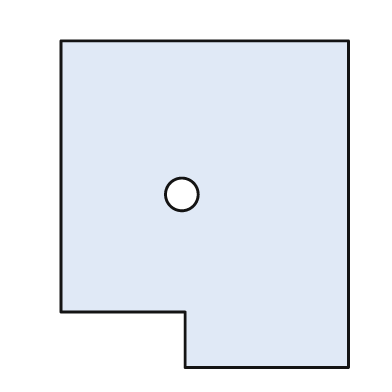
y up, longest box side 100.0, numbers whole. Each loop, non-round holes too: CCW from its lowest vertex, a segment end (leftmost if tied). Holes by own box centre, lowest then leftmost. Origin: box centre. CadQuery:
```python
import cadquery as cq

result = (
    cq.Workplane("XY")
    .moveTo(-6.0, -50.0)
    .lineTo(44.0, -50.0)
    .lineTo(44.0, 50.0)
    .lineTo(-44.0, 50.0)
    .lineTo(-44.0, -33.0)
    .lineTo(-6.0, -33.0)
    .close()
    .moveTo(-7.0, 3.0)
    .circle(5.0)
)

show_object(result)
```